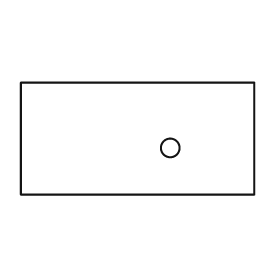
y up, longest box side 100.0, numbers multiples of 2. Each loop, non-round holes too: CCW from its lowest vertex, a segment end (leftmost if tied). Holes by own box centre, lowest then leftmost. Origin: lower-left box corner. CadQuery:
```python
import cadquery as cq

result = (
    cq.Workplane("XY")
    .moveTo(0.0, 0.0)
    .lineTo(100.0, 0.0)
    .lineTo(100.0, 48.0)
    .lineTo(0.0, 48.0)
    .close()
    .moveTo(64.0, 20.0)
    .circle(4.0)
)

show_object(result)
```